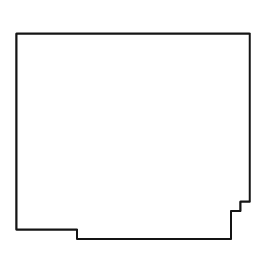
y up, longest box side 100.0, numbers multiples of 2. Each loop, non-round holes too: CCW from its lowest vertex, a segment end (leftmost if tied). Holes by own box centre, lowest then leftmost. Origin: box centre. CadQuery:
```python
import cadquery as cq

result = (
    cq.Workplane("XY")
    .moveTo(-24.0, -44.0)
    .lineTo(42.0, -44.0)
    .lineTo(42.0, -32.0)
    .lineTo(46.0, -32.0)
    .lineTo(46.0, -28.0)
    .lineTo(50.0, -28.0)
    .lineTo(50.0, 44.0)
    .lineTo(-50.0, 44.0)
    .lineTo(-50.0, -40.0)
    .lineTo(-24.0, -40.0)
    .close()
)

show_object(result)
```